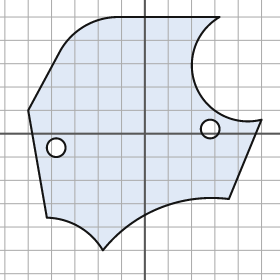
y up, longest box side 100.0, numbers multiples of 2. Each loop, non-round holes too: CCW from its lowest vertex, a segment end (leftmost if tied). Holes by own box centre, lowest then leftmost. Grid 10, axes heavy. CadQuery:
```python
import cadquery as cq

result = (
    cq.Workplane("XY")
    .moveTo(-18.0, -50.0)
    .threePointArc((6.0, -32.0), (36.0, -28.0))
    .lineTo(50.0, 6.0)
    .threePointArc((22.0, 20.0), (32.0, 50.0))
    .lineTo(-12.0, 50.0)
    .threePointArc((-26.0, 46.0), (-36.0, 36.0))
    .lineTo(-50.0, 10.0)
    .lineTo(-42.0, -36.0)
    .threePointArc((-28.0, -40.0), (-18.0, -50.0))
    .close()
    .moveTo(-38.0, -6.0)
    .circle(4.0)
    .moveTo(28.0, 2.0)
    .circle(4.0)
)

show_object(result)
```